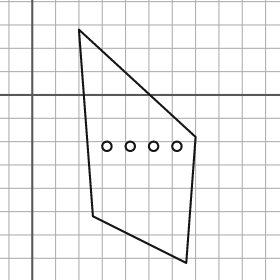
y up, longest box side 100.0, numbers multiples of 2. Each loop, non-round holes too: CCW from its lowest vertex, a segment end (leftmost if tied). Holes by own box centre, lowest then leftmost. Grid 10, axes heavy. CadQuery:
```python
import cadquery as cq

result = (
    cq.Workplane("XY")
    .moveTo(66.0, -72.0)
    .lineTo(70.0, -18.0)
    .lineTo(20.0, 28.0)
    .lineTo(26.0, -52.0)
    .close()
    .moveTo(32.0, -22.0)
    .circle(2.0)
    .moveTo(42.0, -22.0)
    .circle(2.0)
    .moveTo(52.0, -22.0)
    .circle(2.0)
    .moveTo(62.0, -22.0)
    .circle(2.0)
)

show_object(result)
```